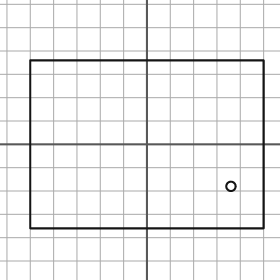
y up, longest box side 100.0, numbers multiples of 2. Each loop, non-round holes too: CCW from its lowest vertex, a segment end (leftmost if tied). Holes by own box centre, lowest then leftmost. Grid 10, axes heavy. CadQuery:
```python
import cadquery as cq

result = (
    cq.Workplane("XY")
    .moveTo(-50.0, -36.0)
    .lineTo(50.0, -36.0)
    .lineTo(50.0, 36.0)
    .lineTo(-50.0, 36.0)
    .close()
    .moveTo(36.0, -18.0)
    .circle(2.0)
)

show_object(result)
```